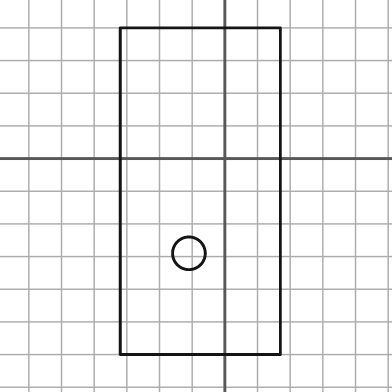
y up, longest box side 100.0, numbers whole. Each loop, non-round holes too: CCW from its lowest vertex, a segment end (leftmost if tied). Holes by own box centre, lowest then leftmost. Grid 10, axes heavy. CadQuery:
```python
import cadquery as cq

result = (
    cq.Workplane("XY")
    .moveTo(-32.0, -60.0)
    .lineTo(17.0, -60.0)
    .lineTo(17.0, 40.0)
    .lineTo(-32.0, 40.0)
    .close()
    .moveTo(-11.0, -29.0)
    .circle(5.0)
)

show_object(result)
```